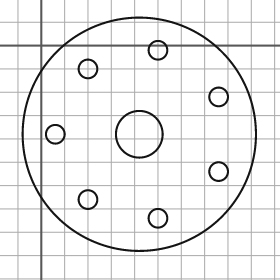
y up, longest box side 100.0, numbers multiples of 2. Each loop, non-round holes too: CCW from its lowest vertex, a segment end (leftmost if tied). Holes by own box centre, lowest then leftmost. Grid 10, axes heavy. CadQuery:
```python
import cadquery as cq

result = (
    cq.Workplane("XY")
    .moveTo(42.0, -38.0)
    .circle(50.0)
    .moveTo(50.0, -74.0)
    .circle(4.0)
    .moveTo(20.0, -66.0)
    .circle(4.0)
    .moveTo(76.0, -54.0)
    .circle(4.0)
    .moveTo(6.0, -38.0)
    .circle(4.0)
    .moveTo(42.0, -38.0)
    .circle(10.0)
    .moveTo(76.0, -22.0)
    .circle(4.0)
    .moveTo(20.0, -10.0)
    .circle(4.0)
    .moveTo(50.0, -2.0)
    .circle(4.0)
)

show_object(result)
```